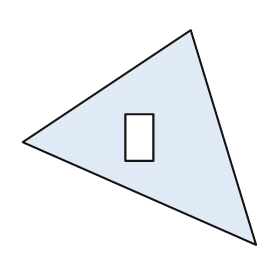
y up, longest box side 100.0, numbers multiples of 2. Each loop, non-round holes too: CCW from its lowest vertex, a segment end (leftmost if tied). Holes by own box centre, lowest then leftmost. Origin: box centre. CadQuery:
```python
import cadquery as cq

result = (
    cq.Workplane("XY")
    .moveTo(50.0, -46.0)
    .lineTo(22.0, 46.0)
    .lineTo(-50.0, -2.0)
    .close()
    .moveTo(-6.0, -10.0)
    .lineTo(6.0, -10.0)
    .lineTo(6.0, 10.0)
    .lineTo(-6.0, 10.0)
    .close()
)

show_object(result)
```